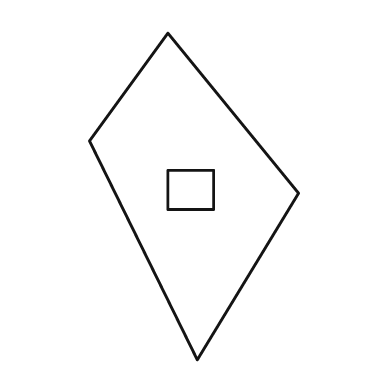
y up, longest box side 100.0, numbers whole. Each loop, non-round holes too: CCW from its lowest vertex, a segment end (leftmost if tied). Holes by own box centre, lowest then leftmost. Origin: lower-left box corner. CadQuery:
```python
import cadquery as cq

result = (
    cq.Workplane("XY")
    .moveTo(33.0, 0.0)
    .lineTo(64.0, 51.0)
    .lineTo(24.0, 100.0)
    .lineTo(0.0, 67.0)
    .close()
    .moveTo(24.0, 46.0)
    .lineTo(38.0, 46.0)
    .lineTo(38.0, 58.0)
    .lineTo(24.0, 58.0)
    .close()
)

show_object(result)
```